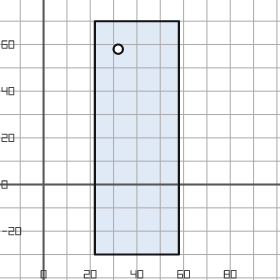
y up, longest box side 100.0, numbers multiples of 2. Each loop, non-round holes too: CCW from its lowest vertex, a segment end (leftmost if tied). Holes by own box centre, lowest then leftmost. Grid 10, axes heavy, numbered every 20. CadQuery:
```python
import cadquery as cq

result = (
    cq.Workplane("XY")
    .moveTo(22.0, -30.0)
    .lineTo(58.0, -30.0)
    .lineTo(58.0, 70.0)
    .lineTo(22.0, 70.0)
    .close()
    .moveTo(32.0, 58.0)
    .circle(2.0)
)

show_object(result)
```